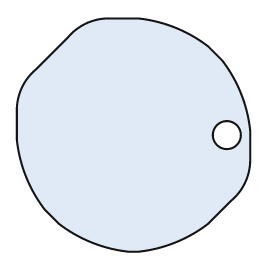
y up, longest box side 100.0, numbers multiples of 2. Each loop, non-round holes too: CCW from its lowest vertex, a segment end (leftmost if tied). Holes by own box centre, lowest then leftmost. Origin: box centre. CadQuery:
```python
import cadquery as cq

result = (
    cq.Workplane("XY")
    .moveTo(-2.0, -50.0)
    .lineTo(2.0, -50.0)
    .threePointArc((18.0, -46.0), (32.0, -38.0))
    .lineTo(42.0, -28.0)
    .threePointArc((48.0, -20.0), (50.0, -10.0))
    .lineTo(50.0, 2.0)
    .threePointArc((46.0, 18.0), (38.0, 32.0))
    .lineTo(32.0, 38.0)
    .threePointArc((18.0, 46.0), (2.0, 50.0))
    .lineTo(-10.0, 50.0)
    .threePointArc((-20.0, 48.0), (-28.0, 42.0))
    .lineTo(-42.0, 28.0)
    .threePointArc((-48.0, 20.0), (-50.0, 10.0))
    .lineTo(-50.0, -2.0)
    .threePointArc((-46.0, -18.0), (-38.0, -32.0))
    .lineTo(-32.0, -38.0)
    .threePointArc((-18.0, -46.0), (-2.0, -50.0))
    .close()
    .moveTo(40.0, 0.0)
    .circle(6.0)
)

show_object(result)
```